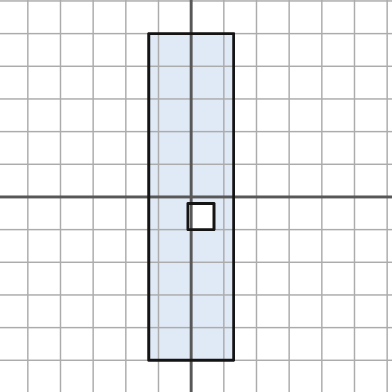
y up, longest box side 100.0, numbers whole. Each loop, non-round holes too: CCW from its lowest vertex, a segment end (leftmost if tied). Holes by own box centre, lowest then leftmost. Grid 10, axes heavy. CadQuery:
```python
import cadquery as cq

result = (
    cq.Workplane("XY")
    .moveTo(-13.0, -50.0)
    .lineTo(13.0, -50.0)
    .lineTo(13.0, 50.0)
    .lineTo(-13.0, 50.0)
    .close()
    .moveTo(-1.0, -10.0)
    .lineTo(7.0, -10.0)
    .lineTo(7.0, -2.0)
    .lineTo(-1.0, -2.0)
    .close()
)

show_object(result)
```